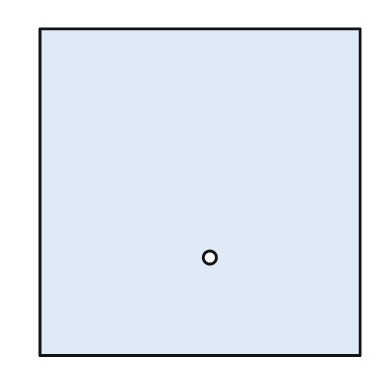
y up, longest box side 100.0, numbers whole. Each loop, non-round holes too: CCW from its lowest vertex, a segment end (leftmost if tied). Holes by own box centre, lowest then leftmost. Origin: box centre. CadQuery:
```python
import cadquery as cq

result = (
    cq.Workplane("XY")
    .moveTo(-49.0, -50.0)
    .lineTo(49.0, -50.0)
    .lineTo(49.0, 50.0)
    .lineTo(-49.0, 50.0)
    .close()
    .moveTo(3.0, -20.0)
    .circle(2.0)
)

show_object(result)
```